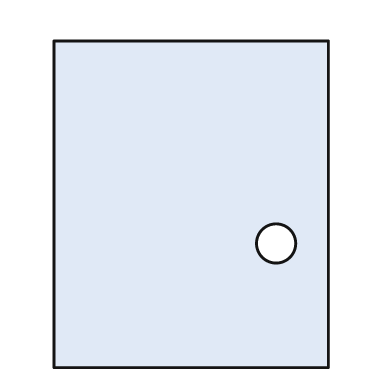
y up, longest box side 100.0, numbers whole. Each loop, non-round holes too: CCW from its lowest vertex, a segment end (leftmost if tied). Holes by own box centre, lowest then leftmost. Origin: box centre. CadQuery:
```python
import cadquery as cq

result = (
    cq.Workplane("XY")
    .moveTo(-42.0, -50.0)
    .lineTo(42.0, -50.0)
    .lineTo(42.0, 50.0)
    .lineTo(-42.0, 50.0)
    .close()
    .moveTo(26.0, -12.0)
    .circle(6.0)
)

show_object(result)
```